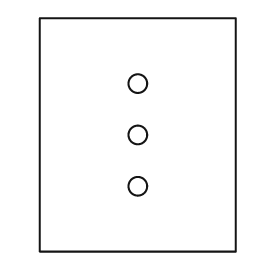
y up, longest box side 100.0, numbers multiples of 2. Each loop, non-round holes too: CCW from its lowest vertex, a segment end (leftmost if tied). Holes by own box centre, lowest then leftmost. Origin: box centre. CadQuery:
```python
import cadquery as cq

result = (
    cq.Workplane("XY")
    .moveTo(-42.0, -50.0)
    .lineTo(42.0, -50.0)
    .lineTo(42.0, 50.0)
    .lineTo(-42.0, 50.0)
    .close()
    .moveTo(0.0, -22.0)
    .circle(4.0)
    .moveTo(0.0, 0.0)
    .circle(4.0)
    .moveTo(0.0, 22.0)
    .circle(4.0)
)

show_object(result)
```